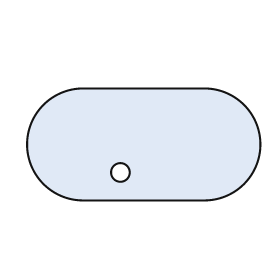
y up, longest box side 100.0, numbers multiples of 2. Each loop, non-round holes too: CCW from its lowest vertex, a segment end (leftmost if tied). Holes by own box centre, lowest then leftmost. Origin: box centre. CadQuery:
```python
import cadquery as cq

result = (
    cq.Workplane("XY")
    .moveTo(-26.0, -24.0)
    .lineTo(26.0, -24.0)
    .threePointArc((50.0, 0.0), (26.0, 24.0))
    .lineTo(-26.0, 24.0)
    .threePointArc((-50.0, 0.0), (-26.0, -24.0))
    .close()
    .moveTo(-10.0, -12.0)
    .circle(4.0)
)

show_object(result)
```